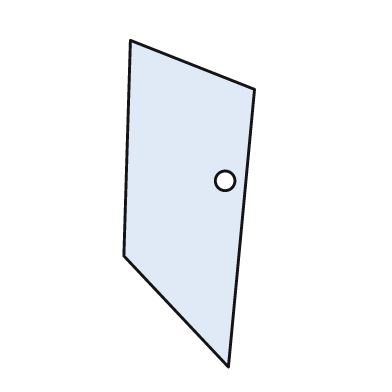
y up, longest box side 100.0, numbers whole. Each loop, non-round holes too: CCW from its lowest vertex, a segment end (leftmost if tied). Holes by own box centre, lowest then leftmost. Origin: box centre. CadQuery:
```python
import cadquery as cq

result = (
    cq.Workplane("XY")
    .moveTo(12.0, -50.0)
    .lineTo(20.0, 35.0)
    .lineTo(-18.0, 50.0)
    .lineTo(-20.0, -16.0)
    .close()
    .moveTo(11.0, 7.0)
    .circle(3.0)
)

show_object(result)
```